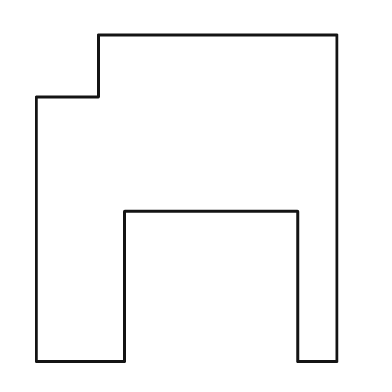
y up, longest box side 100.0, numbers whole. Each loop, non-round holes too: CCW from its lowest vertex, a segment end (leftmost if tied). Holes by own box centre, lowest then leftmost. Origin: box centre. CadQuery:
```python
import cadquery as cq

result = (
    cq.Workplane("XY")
    .moveTo(-46.0, -50.0)
    .lineTo(-19.0, -50.0)
    .lineTo(-19.0, -4.0)
    .lineTo(34.0, -4.0)
    .lineTo(34.0, -50.0)
    .lineTo(46.0, -50.0)
    .lineTo(46.0, 50.0)
    .lineTo(-27.0, 50.0)
    .lineTo(-27.0, 31.0)
    .lineTo(-46.0, 31.0)
    .close()
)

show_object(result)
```